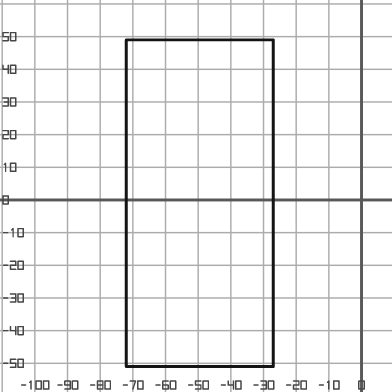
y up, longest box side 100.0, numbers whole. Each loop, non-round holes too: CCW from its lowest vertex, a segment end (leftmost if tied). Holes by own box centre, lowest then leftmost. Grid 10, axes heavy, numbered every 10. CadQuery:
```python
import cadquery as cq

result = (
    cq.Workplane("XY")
    .moveTo(-72.0, -51.0)
    .lineTo(-27.0, -51.0)
    .lineTo(-27.0, 49.0)
    .lineTo(-72.0, 49.0)
    .close()
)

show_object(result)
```